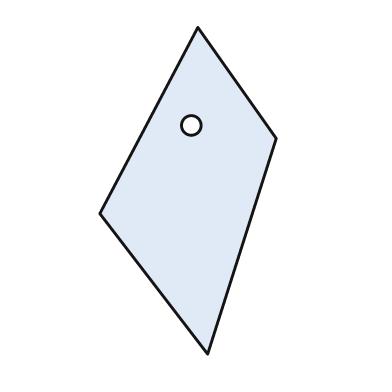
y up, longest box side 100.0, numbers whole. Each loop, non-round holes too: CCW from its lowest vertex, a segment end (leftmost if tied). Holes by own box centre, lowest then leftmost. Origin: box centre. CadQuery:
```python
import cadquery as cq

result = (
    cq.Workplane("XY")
    .moveTo(6.0, -50.0)
    .lineTo(27.0, 16.0)
    .lineTo(3.0, 50.0)
    .lineTo(-27.0, -7.0)
    .close()
    .moveTo(1.0, 20.0)
    .circle(3.0)
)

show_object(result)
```